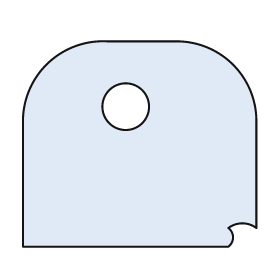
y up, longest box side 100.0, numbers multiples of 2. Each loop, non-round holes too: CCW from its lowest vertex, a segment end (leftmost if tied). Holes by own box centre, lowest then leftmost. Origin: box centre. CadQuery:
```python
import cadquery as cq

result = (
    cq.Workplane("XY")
    .moveTo(-50.0, -44.0)
    .lineTo(38.0, -44.0)
    .threePointArc((40.0, -40.0), (38.0, -36.0))
    .threePointArc((44.0, -34.0), (50.0, -36.0))
    .lineTo(50.0, 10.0)
    .threePointArc((40.0, 34.0), (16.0, 44.0))
    .lineTo(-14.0, 44.0)
    .threePointArc((-40.0, 34.0), (-50.0, 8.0))
    .close()
    .moveTo(-6.0, 16.0)
    .circle(10.0)
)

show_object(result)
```